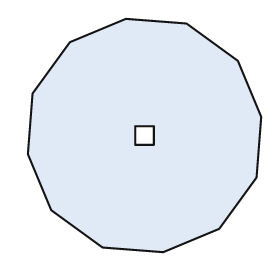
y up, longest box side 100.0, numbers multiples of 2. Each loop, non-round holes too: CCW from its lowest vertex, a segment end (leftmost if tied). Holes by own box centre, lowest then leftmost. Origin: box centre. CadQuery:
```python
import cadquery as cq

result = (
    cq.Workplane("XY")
    .moveTo(8.0, -50.0)
    .lineTo(32.0, -40.0)
    .lineTo(48.0, -18.0)
    .lineTo(50.0, 8.0)
    .lineTo(40.0, 32.0)
    .lineTo(18.0, 48.0)
    .lineTo(-8.0, 50.0)
    .lineTo(-32.0, 40.0)
    .lineTo(-48.0, 18.0)
    .lineTo(-50.0, -8.0)
    .lineTo(-40.0, -32.0)
    .lineTo(-18.0, -48.0)
    .close()
    .moveTo(-4.0, -4.0)
    .lineTo(4.0, -4.0)
    .lineTo(4.0, 4.0)
    .lineTo(-4.0, 4.0)
    .close()
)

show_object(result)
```